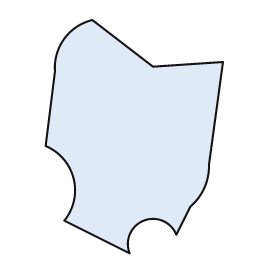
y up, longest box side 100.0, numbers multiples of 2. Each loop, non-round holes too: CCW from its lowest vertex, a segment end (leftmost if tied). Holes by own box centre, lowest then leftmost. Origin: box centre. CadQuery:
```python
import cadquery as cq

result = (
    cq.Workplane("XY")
    .moveTo(-2.0, -50.0)
    .threePointArc((4.0, -36.0), (18.0, -42.0))
    .lineTo(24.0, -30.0)
    .threePointArc((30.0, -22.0), (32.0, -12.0))
    .lineTo(38.0, 32.0)
    .lineTo(8.0, 30.0)
    .lineTo(-18.0, 50.0)
    .threePointArc((-30.0, 42.0), (-34.0, 28.0))
    .lineTo(-38.0, -4.0)
    .threePointArc((-26.0, -18.0), (-30.0, -36.0))
    .close()
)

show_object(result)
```